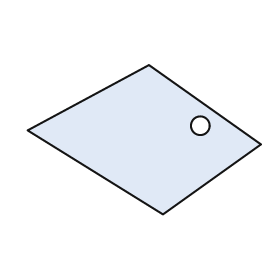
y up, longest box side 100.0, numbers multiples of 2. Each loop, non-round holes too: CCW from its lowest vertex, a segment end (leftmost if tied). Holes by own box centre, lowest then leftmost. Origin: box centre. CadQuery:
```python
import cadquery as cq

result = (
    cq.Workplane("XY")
    .moveTo(8.0, -32.0)
    .lineTo(50.0, -2.0)
    .lineTo(2.0, 32.0)
    .lineTo(-50.0, 4.0)
    .close()
    .moveTo(24.0, 6.0)
    .circle(4.0)
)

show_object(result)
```